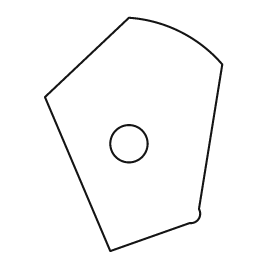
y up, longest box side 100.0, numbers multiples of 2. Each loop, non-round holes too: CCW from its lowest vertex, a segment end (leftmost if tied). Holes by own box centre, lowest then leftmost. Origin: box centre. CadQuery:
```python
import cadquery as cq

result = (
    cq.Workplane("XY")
    .moveTo(-10.0, -50.0)
    .lineTo(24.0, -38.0)
    .threePointArc((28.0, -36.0), (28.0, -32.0))
    .lineTo(38.0, 30.0)
    .threePointArc((20.0, 44.0), (-2.0, 50.0))
    .lineTo(-38.0, 16.0)
    .close()
    .moveTo(-2.0, -4.0)
    .circle(8.0)
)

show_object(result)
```